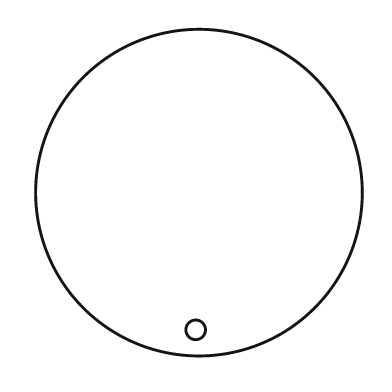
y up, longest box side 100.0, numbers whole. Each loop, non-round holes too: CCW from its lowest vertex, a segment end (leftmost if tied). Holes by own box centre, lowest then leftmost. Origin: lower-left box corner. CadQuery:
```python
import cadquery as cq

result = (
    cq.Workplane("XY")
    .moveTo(50.0, 50.0)
    .circle(50.0)
    .moveTo(49.0, 8.0)
    .circle(3.0)
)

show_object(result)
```